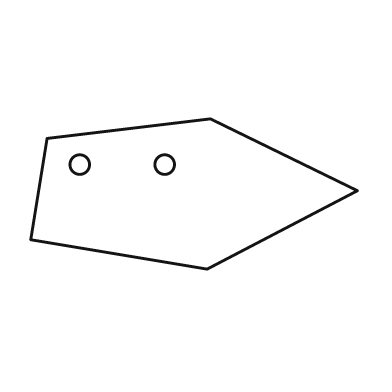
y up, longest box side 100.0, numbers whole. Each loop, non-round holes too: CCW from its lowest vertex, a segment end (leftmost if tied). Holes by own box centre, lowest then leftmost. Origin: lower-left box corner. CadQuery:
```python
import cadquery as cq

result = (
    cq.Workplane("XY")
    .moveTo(54.0, 0.0)
    .lineTo(100.0, 24.0)
    .lineTo(55.0, 46.0)
    .lineTo(5.0, 40.0)
    .lineTo(0.0, 9.0)
    .close()
    .moveTo(15.0, 32.0)
    .circle(3.0)
    .moveTo(41.0, 32.0)
    .circle(3.0)
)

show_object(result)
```